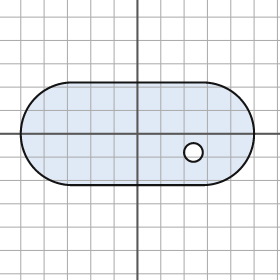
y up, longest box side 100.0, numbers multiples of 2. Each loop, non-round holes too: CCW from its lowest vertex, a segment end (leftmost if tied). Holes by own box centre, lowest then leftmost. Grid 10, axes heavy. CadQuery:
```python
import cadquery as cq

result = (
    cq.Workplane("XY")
    .moveTo(-28.0, -22.0)
    .lineTo(28.0, -22.0)
    .threePointArc((50.0, 0.0), (28.0, 22.0))
    .lineTo(-28.0, 22.0)
    .threePointArc((-50.0, 0.0), (-28.0, -22.0))
    .close()
    .moveTo(24.0, -8.0)
    .circle(4.0)
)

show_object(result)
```